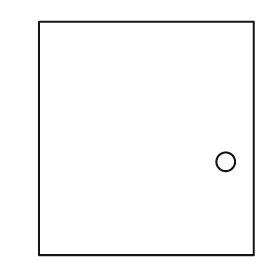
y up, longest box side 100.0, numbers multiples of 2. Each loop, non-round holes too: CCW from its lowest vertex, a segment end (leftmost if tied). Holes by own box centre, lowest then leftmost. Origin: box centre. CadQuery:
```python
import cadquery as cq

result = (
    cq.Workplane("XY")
    .moveTo(-46.0, -50.0)
    .lineTo(46.0, -50.0)
    .lineTo(46.0, 50.0)
    .lineTo(-46.0, 50.0)
    .close()
    .moveTo(34.0, -10.0)
    .circle(4.0)
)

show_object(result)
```